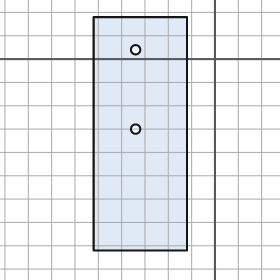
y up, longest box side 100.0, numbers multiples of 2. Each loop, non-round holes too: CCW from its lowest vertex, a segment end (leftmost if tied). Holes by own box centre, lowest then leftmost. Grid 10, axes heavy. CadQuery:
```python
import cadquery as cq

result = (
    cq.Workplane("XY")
    .moveTo(-52.0, -82.0)
    .lineTo(-12.0, -82.0)
    .lineTo(-12.0, 18.0)
    .lineTo(-52.0, 18.0)
    .close()
    .moveTo(-34.0, -30.0)
    .circle(2.0)
    .moveTo(-34.0, 4.0)
    .circle(2.0)
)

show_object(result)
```